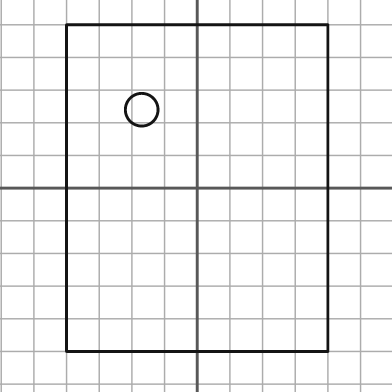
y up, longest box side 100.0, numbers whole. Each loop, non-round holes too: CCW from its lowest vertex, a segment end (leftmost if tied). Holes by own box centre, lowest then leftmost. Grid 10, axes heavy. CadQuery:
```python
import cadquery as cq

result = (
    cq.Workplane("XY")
    .moveTo(-40.0, -50.0)
    .lineTo(40.0, -50.0)
    .lineTo(40.0, 50.0)
    .lineTo(-40.0, 50.0)
    .close()
    .moveTo(-17.0, 24.0)
    .circle(5.0)
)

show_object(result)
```